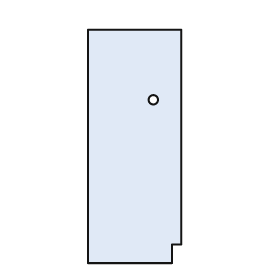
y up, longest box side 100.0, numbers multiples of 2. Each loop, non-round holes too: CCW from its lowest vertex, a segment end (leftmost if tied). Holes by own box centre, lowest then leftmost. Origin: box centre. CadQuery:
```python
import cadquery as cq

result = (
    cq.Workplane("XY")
    .moveTo(-20.0, -50.0)
    .lineTo(16.0, -50.0)
    .lineTo(16.0, -42.0)
    .lineTo(20.0, -42.0)
    .lineTo(20.0, 50.0)
    .lineTo(-20.0, 50.0)
    .close()
    .moveTo(8.0, 20.0)
    .circle(2.0)
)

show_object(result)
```